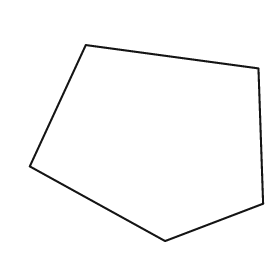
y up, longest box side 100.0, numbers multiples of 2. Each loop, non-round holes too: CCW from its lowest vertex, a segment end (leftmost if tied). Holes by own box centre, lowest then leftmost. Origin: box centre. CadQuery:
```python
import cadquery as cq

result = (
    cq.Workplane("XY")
    .moveTo(8.0, -42.0)
    .lineTo(50.0, -26.0)
    .lineTo(48.0, 32.0)
    .lineTo(-26.0, 42.0)
    .lineTo(-50.0, -10.0)
    .close()
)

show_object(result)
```